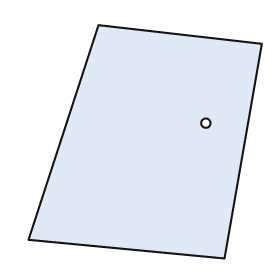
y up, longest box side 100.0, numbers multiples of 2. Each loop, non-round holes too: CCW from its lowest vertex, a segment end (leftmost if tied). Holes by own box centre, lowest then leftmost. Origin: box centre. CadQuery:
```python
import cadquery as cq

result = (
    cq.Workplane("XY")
    .moveTo(34.0, -50.0)
    .lineTo(50.0, 42.0)
    .lineTo(-20.0, 50.0)
    .lineTo(-50.0, -42.0)
    .close()
    .moveTo(26.0, 8.0)
    .circle(2.0)
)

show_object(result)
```